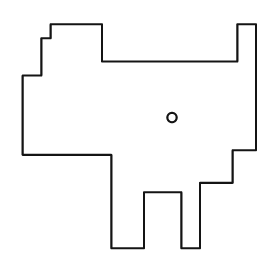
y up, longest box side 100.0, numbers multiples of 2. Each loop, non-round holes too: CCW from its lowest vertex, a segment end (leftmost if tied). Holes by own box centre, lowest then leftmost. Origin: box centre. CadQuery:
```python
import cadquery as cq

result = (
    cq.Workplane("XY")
    .moveTo(-12.0, -48.0)
    .lineTo(2.0, -48.0)
    .lineTo(2.0, -24.0)
    .lineTo(18.0, -24.0)
    .lineTo(18.0, -48.0)
    .lineTo(26.0, -48.0)
    .lineTo(26.0, -20.0)
    .lineTo(40.0, -20.0)
    .lineTo(40.0, -6.0)
    .lineTo(50.0, -6.0)
    .lineTo(50.0, 48.0)
    .lineTo(42.0, 48.0)
    .lineTo(42.0, 32.0)
    .lineTo(-16.0, 32.0)
    .lineTo(-16.0, 48.0)
    .lineTo(-38.0, 48.0)
    .lineTo(-38.0, 42.0)
    .lineTo(-42.0, 42.0)
    .lineTo(-42.0, 26.0)
    .lineTo(-50.0, 26.0)
    .lineTo(-50.0, -8.0)
    .lineTo(-12.0, -8.0)
    .close()
    .moveTo(14.0, 8.0)
    .circle(2.0)
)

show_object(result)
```